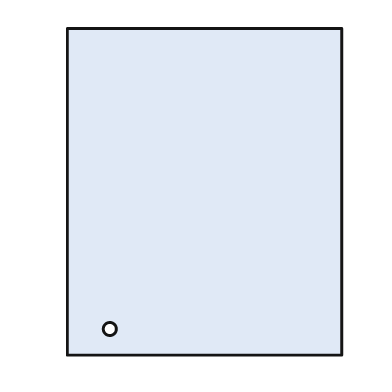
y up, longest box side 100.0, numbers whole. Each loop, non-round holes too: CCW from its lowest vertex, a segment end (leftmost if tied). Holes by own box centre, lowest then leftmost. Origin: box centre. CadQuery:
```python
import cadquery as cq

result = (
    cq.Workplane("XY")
    .moveTo(-42.0, -50.0)
    .lineTo(42.0, -50.0)
    .lineTo(42.0, 50.0)
    .lineTo(-42.0, 50.0)
    .close()
    .moveTo(-29.0, -42.0)
    .circle(2.0)
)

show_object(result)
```